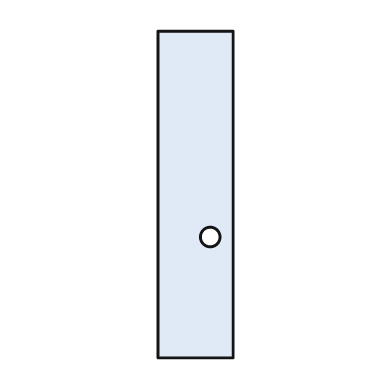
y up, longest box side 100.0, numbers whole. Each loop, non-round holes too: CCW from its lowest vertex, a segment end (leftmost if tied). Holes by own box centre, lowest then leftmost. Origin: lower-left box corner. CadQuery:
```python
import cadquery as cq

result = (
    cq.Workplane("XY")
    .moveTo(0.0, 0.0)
    .lineTo(23.0, 0.0)
    .lineTo(23.0, 100.0)
    .lineTo(0.0, 100.0)
    .close()
    .moveTo(16.0, 37.0)
    .circle(3.0)
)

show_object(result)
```